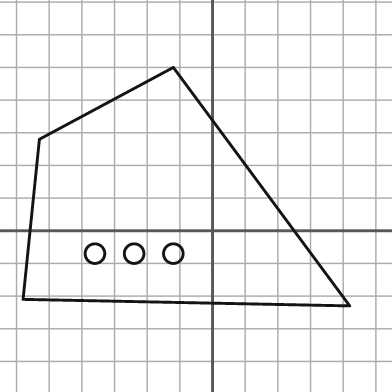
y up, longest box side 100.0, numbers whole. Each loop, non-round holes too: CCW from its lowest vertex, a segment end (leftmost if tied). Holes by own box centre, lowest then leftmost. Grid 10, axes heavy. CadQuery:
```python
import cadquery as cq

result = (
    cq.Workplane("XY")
    .moveTo(42.0, -23.0)
    .lineTo(-12.0, 50.0)
    .lineTo(-53.0, 28.0)
    .lineTo(-58.0, -21.0)
    .close()
    .moveTo(-36.0, -7.0)
    .circle(3.0)
    .moveTo(-24.0, -7.0)
    .circle(3.0)
    .moveTo(-12.0, -7.0)
    .circle(3.0)
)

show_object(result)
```